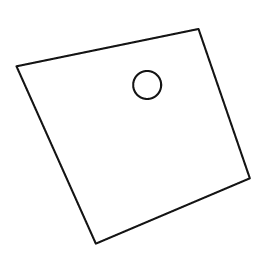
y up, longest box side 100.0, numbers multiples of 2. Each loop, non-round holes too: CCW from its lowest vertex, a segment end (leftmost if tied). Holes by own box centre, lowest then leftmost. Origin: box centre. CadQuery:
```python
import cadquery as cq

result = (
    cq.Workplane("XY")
    .moveTo(-16.0, -46.0)
    .lineTo(50.0, -18.0)
    .lineTo(28.0, 46.0)
    .lineTo(-50.0, 30.0)
    .close()
    .moveTo(6.0, 22.0)
    .circle(6.0)
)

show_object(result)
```